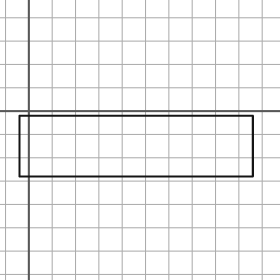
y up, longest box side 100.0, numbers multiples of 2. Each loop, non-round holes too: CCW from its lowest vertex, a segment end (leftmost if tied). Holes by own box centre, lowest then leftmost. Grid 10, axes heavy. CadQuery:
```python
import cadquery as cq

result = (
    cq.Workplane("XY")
    .moveTo(-4.0, -28.0)
    .lineTo(96.0, -28.0)
    .lineTo(96.0, -2.0)
    .lineTo(-4.0, -2.0)
    .close()
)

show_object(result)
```